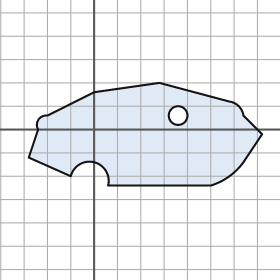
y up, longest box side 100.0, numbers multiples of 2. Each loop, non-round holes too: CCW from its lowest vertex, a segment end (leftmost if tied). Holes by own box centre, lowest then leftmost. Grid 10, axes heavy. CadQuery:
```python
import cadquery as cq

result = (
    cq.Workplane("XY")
    .moveTo(6.0, -24.0)
    .lineTo(50.0, -24.0)
    .threePointArc((58.0, -20.0), (64.0, -14.0))
    .lineTo(72.0, -2.0)
    .lineTo(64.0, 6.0)
    .threePointArc((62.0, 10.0), (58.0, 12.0))
    .lineTo(28.0, 20.0)
    .lineTo(0.0, 16.0)
    .lineTo(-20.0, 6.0)
    .threePointArc((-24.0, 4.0), (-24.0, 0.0))
    .lineTo(-28.0, -12.0)
    .lineTo(-10.0, -20.0)
    .threePointArc((0.0, -14.0), (6.0, -24.0))
    .close()
    .moveTo(36.0, 6.0)
    .circle(4.0)
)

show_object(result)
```